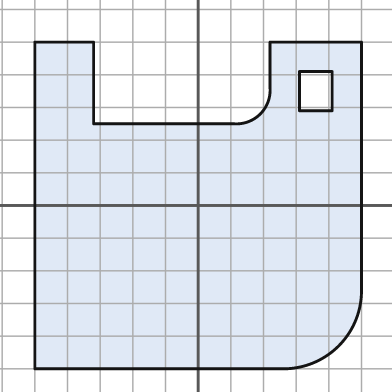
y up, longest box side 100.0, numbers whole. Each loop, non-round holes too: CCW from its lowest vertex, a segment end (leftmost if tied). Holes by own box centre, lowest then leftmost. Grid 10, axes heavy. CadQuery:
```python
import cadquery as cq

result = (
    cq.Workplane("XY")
    .moveTo(-50.0, -50.0)
    .lineTo(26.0, -50.0)
    .threePointArc((43.0, -43.0), (50.0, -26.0))
    .lineTo(50.0, 50.0)
    .lineTo(22.0, 50.0)
    .lineTo(22.0, 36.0)
    .threePointArc((19.0, 28.0), (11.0, 25.0))
    .lineTo(-32.0, 25.0)
    .lineTo(-32.0, 50.0)
    .lineTo(-50.0, 50.0)
    .close()
    .moveTo(31.0, 29.0)
    .lineTo(41.0, 29.0)
    .lineTo(41.0, 41.0)
    .lineTo(31.0, 41.0)
    .close()
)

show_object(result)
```